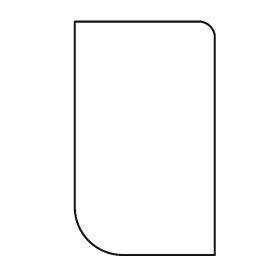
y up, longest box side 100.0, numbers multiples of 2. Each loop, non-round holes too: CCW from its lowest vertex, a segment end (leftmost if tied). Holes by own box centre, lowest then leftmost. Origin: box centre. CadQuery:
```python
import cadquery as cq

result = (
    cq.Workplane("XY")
    .moveTo(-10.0, -50.0)
    .lineTo(30.0, -50.0)
    .lineTo(30.0, 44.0)
    .threePointArc((28.0, 48.0), (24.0, 50.0))
    .lineTo(-30.0, 50.0)
    .lineTo(-30.0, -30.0)
    .threePointArc((-24.0, -44.0), (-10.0, -50.0))
    .close()
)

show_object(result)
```